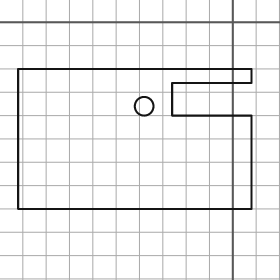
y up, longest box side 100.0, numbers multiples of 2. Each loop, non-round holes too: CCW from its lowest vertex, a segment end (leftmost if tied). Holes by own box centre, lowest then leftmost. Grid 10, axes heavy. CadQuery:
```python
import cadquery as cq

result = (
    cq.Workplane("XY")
    .moveTo(-92.0, -80.0)
    .lineTo(8.0, -80.0)
    .lineTo(8.0, -40.0)
    .lineTo(-26.0, -40.0)
    .lineTo(-26.0, -26.0)
    .lineTo(8.0, -26.0)
    .lineTo(8.0, -20.0)
    .lineTo(-92.0, -20.0)
    .close()
    .moveTo(-38.0, -36.0)
    .circle(4.0)
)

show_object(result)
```